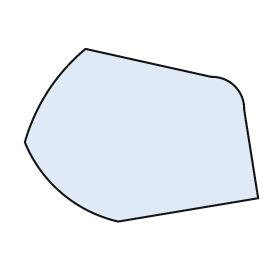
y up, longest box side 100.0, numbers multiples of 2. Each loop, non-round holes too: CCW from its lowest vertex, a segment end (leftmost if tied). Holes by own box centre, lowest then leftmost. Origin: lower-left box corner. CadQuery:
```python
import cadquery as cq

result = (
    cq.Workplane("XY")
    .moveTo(40.0, 0.0)
    .lineTo(100.0, 10.0)
    .lineTo(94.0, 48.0)
    .threePointArc((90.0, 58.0), (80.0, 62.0))
    .lineTo(26.0, 74.0)
    .threePointArc((10.0, 56.0), (0.0, 34.0))
    .threePointArc((16.0, 12.0), (40.0, 0.0))
    .close()
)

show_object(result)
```